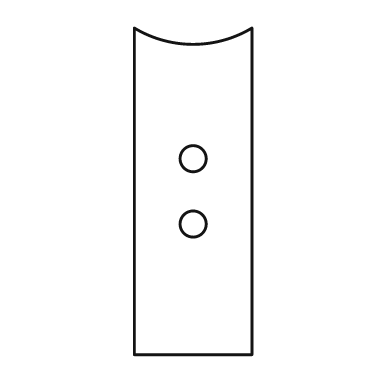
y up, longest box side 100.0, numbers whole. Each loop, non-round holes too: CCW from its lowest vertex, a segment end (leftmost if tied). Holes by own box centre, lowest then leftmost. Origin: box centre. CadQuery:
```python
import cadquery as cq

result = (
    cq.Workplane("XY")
    .moveTo(-18.0, -50.0)
    .lineTo(18.0, -50.0)
    .lineTo(18.0, 50.0)
    .threePointArc((0.0, 45.0), (-18.0, 50.0))
    .close()
    .moveTo(0.0, -10.0)
    .circle(4.0)
    .moveTo(0.0, 10.0)
    .circle(4.0)
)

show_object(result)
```